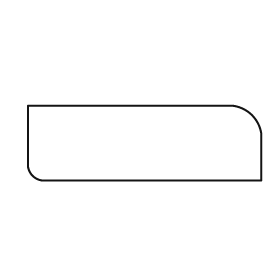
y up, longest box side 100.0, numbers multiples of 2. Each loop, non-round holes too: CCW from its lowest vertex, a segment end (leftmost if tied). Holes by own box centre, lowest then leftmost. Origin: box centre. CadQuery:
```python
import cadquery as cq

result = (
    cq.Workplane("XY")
    .moveTo(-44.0, -16.0)
    .lineTo(50.0, -16.0)
    .lineTo(50.0, 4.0)
    .threePointArc((46.0, 12.0), (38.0, 16.0))
    .lineTo(-50.0, 16.0)
    .lineTo(-50.0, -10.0)
    .threePointArc((-48.0, -14.0), (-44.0, -16.0))
    .close()
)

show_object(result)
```